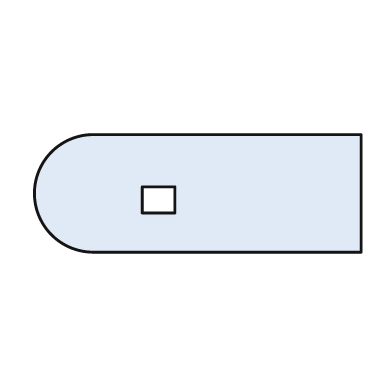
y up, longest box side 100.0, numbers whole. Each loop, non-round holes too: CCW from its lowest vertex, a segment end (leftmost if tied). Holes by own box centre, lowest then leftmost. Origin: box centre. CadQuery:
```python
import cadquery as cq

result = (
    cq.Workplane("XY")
    .moveTo(-32.0, -18.0)
    .lineTo(50.0, -18.0)
    .lineTo(50.0, 18.0)
    .lineTo(-32.0, 18.0)
    .threePointArc((-50.0, 0.0), (-32.0, -18.0))
    .close()
    .moveTo(-17.0, -6.0)
    .lineTo(-7.0, -6.0)
    .lineTo(-7.0, 2.0)
    .lineTo(-17.0, 2.0)
    .close()
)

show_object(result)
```